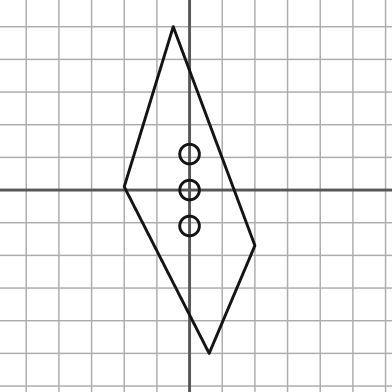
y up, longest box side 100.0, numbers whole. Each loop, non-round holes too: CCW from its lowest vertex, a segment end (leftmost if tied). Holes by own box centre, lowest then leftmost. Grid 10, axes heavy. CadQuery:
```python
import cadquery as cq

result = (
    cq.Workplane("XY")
    .moveTo(6.0, -50.0)
    .lineTo(20.0, -17.0)
    .lineTo(-5.0, 50.0)
    .lineTo(-20.0, 1.0)
    .close()
    .moveTo(0.0, -11.0)
    .circle(3.0)
    .moveTo(0.0, 0.0)
    .circle(3.0)
    .moveTo(0.0, 11.0)
    .circle(3.0)
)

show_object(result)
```